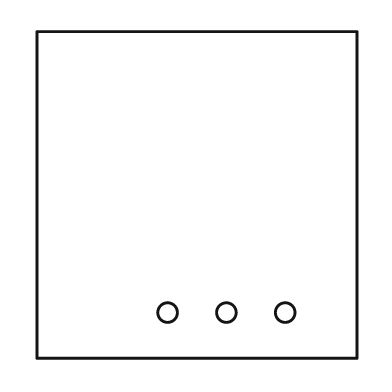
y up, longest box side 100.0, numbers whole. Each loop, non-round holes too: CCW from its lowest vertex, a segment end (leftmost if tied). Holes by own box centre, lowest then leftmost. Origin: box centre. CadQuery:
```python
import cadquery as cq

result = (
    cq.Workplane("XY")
    .moveTo(-49.0, -50.0)
    .lineTo(49.0, -50.0)
    .lineTo(49.0, 50.0)
    .lineTo(-49.0, 50.0)
    .close()
    .moveTo(-9.0, -36.0)
    .circle(3.0)
    .moveTo(9.0, -36.0)
    .circle(3.0)
    .moveTo(27.0, -36.0)
    .circle(3.0)
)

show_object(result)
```